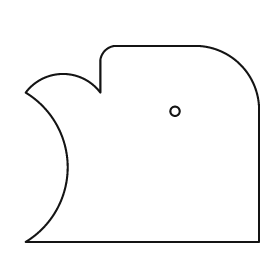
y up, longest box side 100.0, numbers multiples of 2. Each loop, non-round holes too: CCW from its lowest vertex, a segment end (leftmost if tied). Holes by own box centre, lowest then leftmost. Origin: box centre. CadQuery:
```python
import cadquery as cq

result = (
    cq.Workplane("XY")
    .moveTo(-50.0, -42.0)
    .lineTo(50.0, -42.0)
    .lineTo(50.0, 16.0)
    .threePointArc((42.0, 34.0), (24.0, 42.0))
    .lineTo(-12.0, 42.0)
    .threePointArc((-16.0, 40.0), (-18.0, 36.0))
    .lineTo(-18.0, 22.0)
    .threePointArc((-34.0, 30.0), (-50.0, 22.0))
    .threePointArc((-32.0, -10.0), (-50.0, -42.0))
    .close()
    .moveTo(14.0, 14.0)
    .circle(2.0)
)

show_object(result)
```